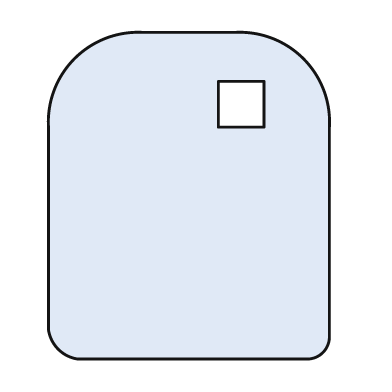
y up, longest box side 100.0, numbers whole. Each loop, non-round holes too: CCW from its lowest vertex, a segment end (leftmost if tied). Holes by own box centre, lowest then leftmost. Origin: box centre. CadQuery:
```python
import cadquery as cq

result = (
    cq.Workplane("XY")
    .moveTo(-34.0, -50.0)
    .lineTo(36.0, -50.0)
    .threePointArc((41.0, -48.0), (43.0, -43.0))
    .lineTo(43.0, 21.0)
    .threePointArc((35.0, 42.0), (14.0, 50.0))
    .lineTo(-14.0, 50.0)
    .threePointArc((-35.0, 42.0), (-43.0, 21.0))
    .lineTo(-43.0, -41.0)
    .threePointArc((-40.0, -47.0), (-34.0, -50.0))
    .close()
    .moveTo(9.0, 21.0)
    .lineTo(23.0, 21.0)
    .lineTo(23.0, 35.0)
    .lineTo(9.0, 35.0)
    .close()
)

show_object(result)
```